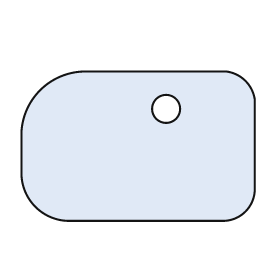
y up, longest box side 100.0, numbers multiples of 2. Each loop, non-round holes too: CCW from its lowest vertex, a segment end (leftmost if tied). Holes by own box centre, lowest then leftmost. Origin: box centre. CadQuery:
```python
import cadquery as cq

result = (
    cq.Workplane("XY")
    .moveTo(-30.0, -32.0)
    .lineTo(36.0, -32.0)
    .threePointArc((46.0, -28.0), (50.0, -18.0))
    .lineTo(50.0, 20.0)
    .threePointArc((46.0, 28.0), (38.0, 32.0))
    .lineTo(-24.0, 32.0)
    .threePointArc((-42.0, 24.0), (-50.0, 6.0))
    .lineTo(-50.0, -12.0)
    .threePointArc((-44.0, -26.0), (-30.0, -32.0))
    .close()
    .moveTo(12.0, 16.0)
    .circle(6.0)
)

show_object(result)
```